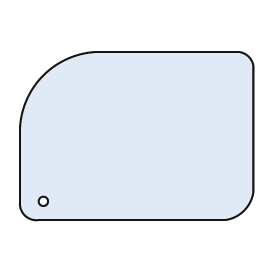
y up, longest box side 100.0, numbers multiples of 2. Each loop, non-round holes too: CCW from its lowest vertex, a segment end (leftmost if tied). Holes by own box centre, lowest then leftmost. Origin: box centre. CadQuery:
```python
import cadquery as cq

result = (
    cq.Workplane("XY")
    .moveTo(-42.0, -36.0)
    .lineTo(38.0, -36.0)
    .threePointArc((46.0, -32.0), (50.0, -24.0))
    .lineTo(50.0, 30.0)
    .threePointArc((48.0, 34.0), (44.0, 36.0))
    .lineTo(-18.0, 36.0)
    .threePointArc((-40.0, 26.0), (-50.0, 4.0))
    .lineTo(-50.0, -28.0)
    .threePointArc((-48.0, -34.0), (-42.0, -36.0))
    .close()
    .moveTo(-40.0, -28.0)
    .circle(2.0)
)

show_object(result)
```